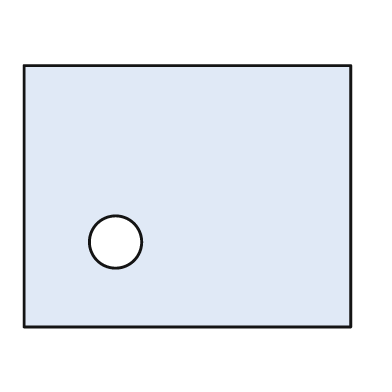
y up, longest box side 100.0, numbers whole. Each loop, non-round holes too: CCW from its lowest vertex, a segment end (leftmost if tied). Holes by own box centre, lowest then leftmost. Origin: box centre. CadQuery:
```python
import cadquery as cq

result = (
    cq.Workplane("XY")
    .moveTo(-50.0, -40.0)
    .lineTo(50.0, -40.0)
    .lineTo(50.0, 40.0)
    .lineTo(-50.0, 40.0)
    .close()
    .moveTo(-22.0, -14.0)
    .circle(8.0)
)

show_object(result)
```